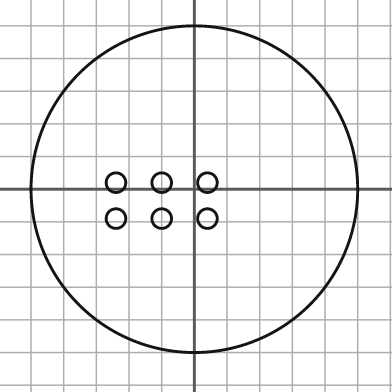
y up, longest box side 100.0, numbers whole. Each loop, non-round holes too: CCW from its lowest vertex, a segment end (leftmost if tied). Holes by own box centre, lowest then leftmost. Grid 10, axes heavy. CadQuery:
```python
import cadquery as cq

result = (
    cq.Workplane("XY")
    .moveTo(0.0, 0.0)
    .circle(50.0)
    .moveTo(-24.0, -9.0)
    .circle(3.0)
    .moveTo(-10.0, -9.0)
    .circle(3.0)
    .moveTo(4.0, -9.0)
    .circle(3.0)
    .moveTo(-24.0, 2.0)
    .circle(3.0)
    .moveTo(-10.0, 2.0)
    .circle(3.0)
    .moveTo(4.0, 2.0)
    .circle(3.0)
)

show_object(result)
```